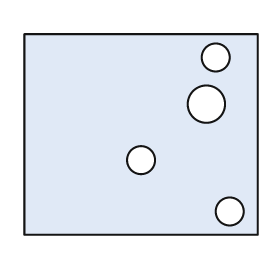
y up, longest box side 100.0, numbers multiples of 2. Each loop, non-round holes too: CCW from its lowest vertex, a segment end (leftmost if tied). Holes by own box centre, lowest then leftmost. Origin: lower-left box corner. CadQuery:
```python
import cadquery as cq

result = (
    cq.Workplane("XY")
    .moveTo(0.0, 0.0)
    .lineTo(100.0, 0.0)
    .lineTo(100.0, 86.0)
    .lineTo(0.0, 86.0)
    .close()
    .moveTo(88.0, 10.0)
    .circle(6.0)
    .moveTo(50.0, 32.0)
    .circle(6.0)
    .moveTo(78.0, 56.0)
    .circle(8.0)
    .moveTo(82.0, 76.0)
    .circle(6.0)
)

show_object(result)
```